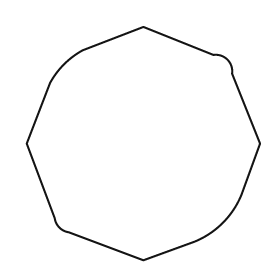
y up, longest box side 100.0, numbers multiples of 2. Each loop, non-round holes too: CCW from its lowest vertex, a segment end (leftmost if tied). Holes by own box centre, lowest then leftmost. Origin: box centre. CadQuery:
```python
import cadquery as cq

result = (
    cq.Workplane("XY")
    .moveTo(0.0, -50.0)
    .lineTo(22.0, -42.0)
    .threePointArc((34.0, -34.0), (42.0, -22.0))
    .lineTo(50.0, 0.0)
    .lineTo(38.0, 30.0)
    .threePointArc((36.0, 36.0), (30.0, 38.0))
    .lineTo(0.0, 50.0)
    .lineTo(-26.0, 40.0)
    .threePointArc((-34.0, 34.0), (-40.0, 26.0))
    .lineTo(-50.0, 0.0)
    .lineTo(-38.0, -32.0)
    .threePointArc((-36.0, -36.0), (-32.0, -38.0))
    .close()
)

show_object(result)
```